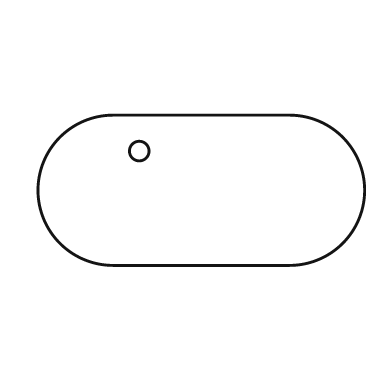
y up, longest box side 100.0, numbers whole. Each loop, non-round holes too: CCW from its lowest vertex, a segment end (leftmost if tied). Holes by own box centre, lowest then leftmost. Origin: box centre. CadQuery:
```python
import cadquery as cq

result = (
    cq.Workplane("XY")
    .moveTo(-27.0, -23.0)
    .lineTo(27.0, -23.0)
    .threePointArc((50.0, 0.0), (27.0, 23.0))
    .lineTo(-27.0, 23.0)
    .threePointArc((-50.0, 0.0), (-27.0, -23.0))
    .close()
    .moveTo(-19.0, 12.0)
    .circle(3.0)
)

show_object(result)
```